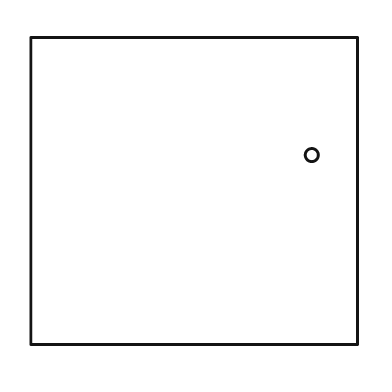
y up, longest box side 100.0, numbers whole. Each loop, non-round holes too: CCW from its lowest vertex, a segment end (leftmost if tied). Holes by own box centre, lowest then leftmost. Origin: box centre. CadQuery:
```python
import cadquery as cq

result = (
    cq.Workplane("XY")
    .moveTo(-50.0, -47.0)
    .lineTo(50.0, -47.0)
    .lineTo(50.0, 47.0)
    .lineTo(-50.0, 47.0)
    .close()
    .moveTo(36.0, 11.0)
    .circle(2.0)
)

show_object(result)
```